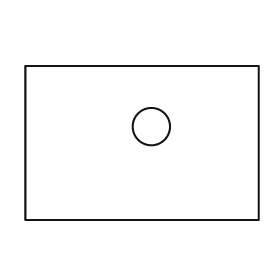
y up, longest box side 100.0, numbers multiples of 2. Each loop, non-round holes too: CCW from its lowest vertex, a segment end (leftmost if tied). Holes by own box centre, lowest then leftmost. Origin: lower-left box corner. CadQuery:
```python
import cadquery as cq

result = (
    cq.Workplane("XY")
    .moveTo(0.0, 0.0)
    .lineTo(100.0, 0.0)
    .lineTo(100.0, 66.0)
    .lineTo(0.0, 66.0)
    .close()
    .moveTo(54.0, 40.0)
    .circle(8.0)
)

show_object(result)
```